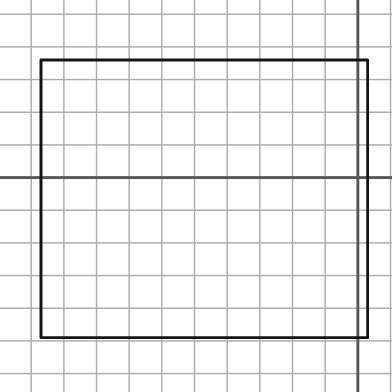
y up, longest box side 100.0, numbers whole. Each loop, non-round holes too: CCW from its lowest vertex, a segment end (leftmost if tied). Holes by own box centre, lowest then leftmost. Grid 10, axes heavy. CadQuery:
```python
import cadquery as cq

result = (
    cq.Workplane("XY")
    .moveTo(-97.0, -49.0)
    .lineTo(3.0, -49.0)
    .lineTo(3.0, 36.0)
    .lineTo(-97.0, 36.0)
    .close()
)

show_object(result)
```